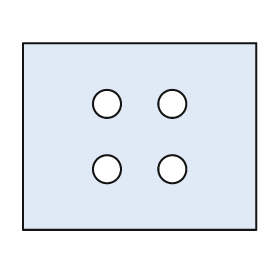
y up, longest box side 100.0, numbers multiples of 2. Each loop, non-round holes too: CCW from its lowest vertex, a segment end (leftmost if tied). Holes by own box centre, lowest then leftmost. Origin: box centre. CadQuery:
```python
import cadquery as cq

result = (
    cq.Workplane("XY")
    .moveTo(-50.0, -40.0)
    .lineTo(50.0, -40.0)
    .lineTo(50.0, 40.0)
    .lineTo(-50.0, 40.0)
    .close()
    .moveTo(-14.0, -14.0)
    .circle(6.0)
    .moveTo(14.0, -14.0)
    .circle(6.0)
    .moveTo(-14.0, 14.0)
    .circle(6.0)
    .moveTo(14.0, 14.0)
    .circle(6.0)
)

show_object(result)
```